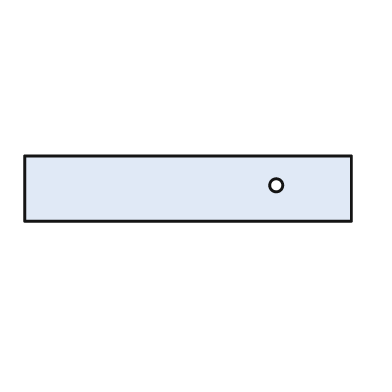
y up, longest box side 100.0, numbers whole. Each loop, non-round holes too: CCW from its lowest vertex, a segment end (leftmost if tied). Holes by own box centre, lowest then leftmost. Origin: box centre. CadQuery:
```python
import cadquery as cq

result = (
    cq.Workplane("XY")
    .moveTo(-50.0, -10.0)
    .lineTo(50.0, -10.0)
    .lineTo(50.0, 10.0)
    .lineTo(-50.0, 10.0)
    .close()
    .moveTo(27.0, 1.0)
    .circle(2.0)
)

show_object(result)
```